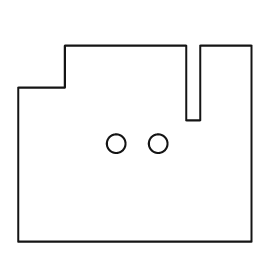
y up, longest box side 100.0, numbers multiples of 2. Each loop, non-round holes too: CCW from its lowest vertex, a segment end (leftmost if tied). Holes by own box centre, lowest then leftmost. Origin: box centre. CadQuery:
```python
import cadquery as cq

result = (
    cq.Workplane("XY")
    .moveTo(-50.0, -42.0)
    .lineTo(50.0, -42.0)
    .lineTo(50.0, 42.0)
    .lineTo(28.0, 42.0)
    .lineTo(28.0, 10.0)
    .lineTo(22.0, 10.0)
    .lineTo(22.0, 42.0)
    .lineTo(-30.0, 42.0)
    .lineTo(-30.0, 24.0)
    .lineTo(-50.0, 24.0)
    .close()
    .moveTo(-8.0, 0.0)
    .circle(4.0)
    .moveTo(10.0, 0.0)
    .circle(4.0)
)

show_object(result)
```